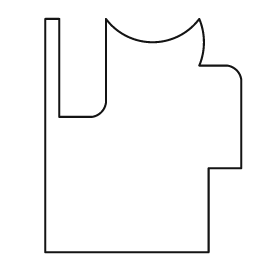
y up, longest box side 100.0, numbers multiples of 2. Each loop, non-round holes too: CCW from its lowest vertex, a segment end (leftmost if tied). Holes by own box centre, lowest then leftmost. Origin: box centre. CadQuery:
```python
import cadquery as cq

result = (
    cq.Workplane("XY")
    .moveTo(-42.0, -50.0)
    .lineTo(28.0, -50.0)
    .lineTo(28.0, -14.0)
    .lineTo(42.0, -14.0)
    .lineTo(42.0, 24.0)
    .threePointArc((40.0, 28.0), (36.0, 30.0))
    .lineTo(24.0, 30.0)
    .threePointArc((26.0, 40.0), (24.0, 50.0))
    .threePointArc((4.0, 40.0), (-16.0, 50.0))
    .lineTo(-16.0, 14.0)
    .threePointArc((-18.0, 10.0), (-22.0, 8.0))
    .lineTo(-36.0, 8.0)
    .lineTo(-36.0, 50.0)
    .lineTo(-42.0, 50.0)
    .close()
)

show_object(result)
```